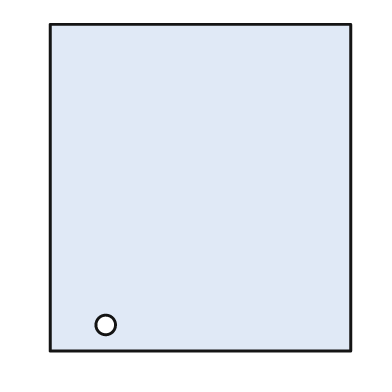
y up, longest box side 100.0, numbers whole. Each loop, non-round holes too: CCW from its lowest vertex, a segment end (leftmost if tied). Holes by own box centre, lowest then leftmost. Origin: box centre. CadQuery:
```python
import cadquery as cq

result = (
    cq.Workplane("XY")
    .moveTo(-46.0, -50.0)
    .lineTo(46.0, -50.0)
    .lineTo(46.0, 50.0)
    .lineTo(-46.0, 50.0)
    .close()
    .moveTo(-29.0, -42.0)
    .circle(3.0)
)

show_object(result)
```